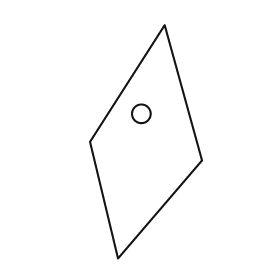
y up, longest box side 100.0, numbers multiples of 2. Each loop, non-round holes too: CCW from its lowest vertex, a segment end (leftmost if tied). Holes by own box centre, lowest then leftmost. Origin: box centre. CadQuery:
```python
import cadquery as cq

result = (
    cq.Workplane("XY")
    .moveTo(-12.0, -50.0)
    .lineTo(24.0, -8.0)
    .lineTo(8.0, 50.0)
    .lineTo(-24.0, 0.0)
    .close()
    .moveTo(-2.0, 12.0)
    .circle(4.0)
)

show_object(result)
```